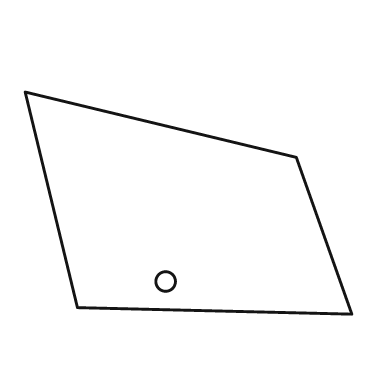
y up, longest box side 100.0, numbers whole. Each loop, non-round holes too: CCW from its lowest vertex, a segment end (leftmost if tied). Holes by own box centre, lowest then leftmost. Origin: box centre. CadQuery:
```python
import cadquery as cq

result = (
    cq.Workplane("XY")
    .moveTo(50.0, -34.0)
    .lineTo(33.0, 14.0)
    .lineTo(-50.0, 34.0)
    .lineTo(-34.0, -32.0)
    .close()
    .moveTo(-7.0, -24.0)
    .circle(3.0)
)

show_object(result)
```